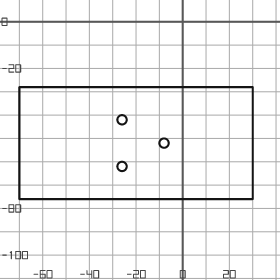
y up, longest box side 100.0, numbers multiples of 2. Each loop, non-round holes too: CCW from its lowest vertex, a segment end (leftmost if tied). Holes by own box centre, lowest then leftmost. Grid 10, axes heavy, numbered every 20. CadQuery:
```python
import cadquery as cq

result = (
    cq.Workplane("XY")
    .moveTo(-70.0, -76.0)
    .lineTo(30.0, -76.0)
    .lineTo(30.0, -28.0)
    .lineTo(-70.0, -28.0)
    .close()
    .moveTo(-26.0, -62.0)
    .circle(2.0)
    .moveTo(-8.0, -52.0)
    .circle(2.0)
    .moveTo(-26.0, -42.0)
    .circle(2.0)
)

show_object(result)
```